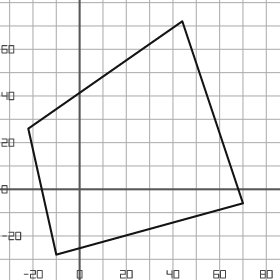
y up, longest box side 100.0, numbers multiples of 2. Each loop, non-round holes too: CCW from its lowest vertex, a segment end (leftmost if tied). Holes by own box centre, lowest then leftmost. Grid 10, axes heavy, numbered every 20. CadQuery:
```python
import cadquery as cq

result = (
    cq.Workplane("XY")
    .moveTo(-10.0, -28.0)
    .lineTo(70.0, -6.0)
    .lineTo(44.0, 72.0)
    .lineTo(-22.0, 26.0)
    .close()
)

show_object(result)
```